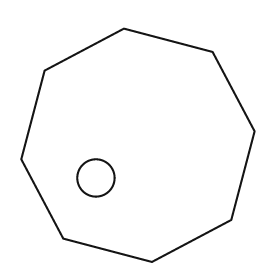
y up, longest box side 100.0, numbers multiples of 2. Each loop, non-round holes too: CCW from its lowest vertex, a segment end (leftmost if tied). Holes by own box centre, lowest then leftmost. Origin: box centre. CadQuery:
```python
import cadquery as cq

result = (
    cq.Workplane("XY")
    .moveTo(6.0, -50.0)
    .lineTo(40.0, -32.0)
    .lineTo(50.0, 6.0)
    .lineTo(32.0, 40.0)
    .lineTo(-6.0, 50.0)
    .lineTo(-40.0, 32.0)
    .lineTo(-50.0, -6.0)
    .lineTo(-32.0, -40.0)
    .close()
    .moveTo(-18.0, -14.0)
    .circle(8.0)
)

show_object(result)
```